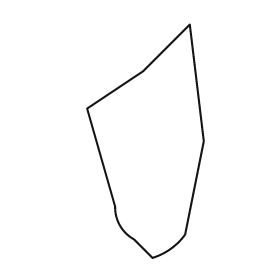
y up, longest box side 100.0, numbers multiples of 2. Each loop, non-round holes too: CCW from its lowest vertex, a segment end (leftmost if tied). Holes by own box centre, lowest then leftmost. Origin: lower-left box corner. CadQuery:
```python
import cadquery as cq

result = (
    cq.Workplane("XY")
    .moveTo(28.0, 0.0)
    .threePointArc((36.0, 4.0), (42.0, 10.0))
    .lineTo(50.0, 50.0)
    .lineTo(44.0, 100.0)
    .lineTo(24.0, 80.0)
    .lineTo(0.0, 64.0)
    .lineTo(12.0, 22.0)
    .threePointArc((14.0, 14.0), (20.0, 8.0))
    .close()
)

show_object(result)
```